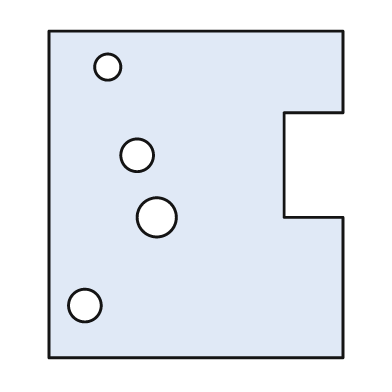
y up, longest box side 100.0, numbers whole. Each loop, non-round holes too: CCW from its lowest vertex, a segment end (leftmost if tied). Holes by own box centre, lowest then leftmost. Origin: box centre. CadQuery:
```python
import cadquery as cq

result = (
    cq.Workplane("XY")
    .moveTo(-45.0, -50.0)
    .lineTo(45.0, -50.0)
    .lineTo(45.0, -7.0)
    .lineTo(27.0, -7.0)
    .lineTo(27.0, 25.0)
    .lineTo(45.0, 25.0)
    .lineTo(45.0, 50.0)
    .lineTo(-45.0, 50.0)
    .close()
    .moveTo(-34.0, -34.0)
    .circle(5.0)
    .moveTo(-12.0, -7.0)
    .circle(6.0)
    .moveTo(-18.0, 12.0)
    .circle(5.0)
    .moveTo(-27.0, 39.0)
    .circle(4.0)
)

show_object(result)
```